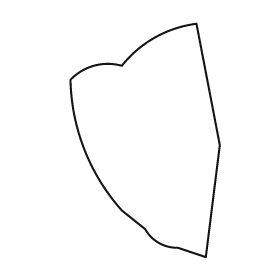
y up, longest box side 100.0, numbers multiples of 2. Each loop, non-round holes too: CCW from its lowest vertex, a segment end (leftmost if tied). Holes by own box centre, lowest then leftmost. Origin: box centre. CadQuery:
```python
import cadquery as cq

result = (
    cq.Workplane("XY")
    .moveTo(26.0, -50.0)
    .lineTo(32.0, -2.0)
    .lineTo(22.0, 50.0)
    .threePointArc((4.0, 44.0), (-10.0, 32.0))
    .threePointArc((-22.0, 32.0), (-32.0, 26.0))
    .threePointArc((-26.0, -4.0), (-10.0, -30.0))
    .lineTo(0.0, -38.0)
    .threePointArc((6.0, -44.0), (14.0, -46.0))
    .close()
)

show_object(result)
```